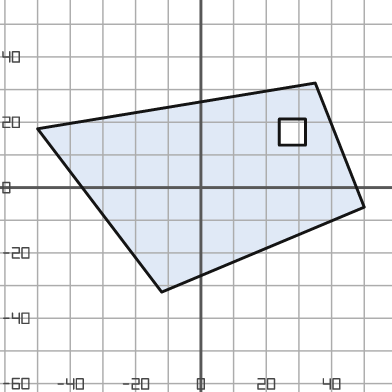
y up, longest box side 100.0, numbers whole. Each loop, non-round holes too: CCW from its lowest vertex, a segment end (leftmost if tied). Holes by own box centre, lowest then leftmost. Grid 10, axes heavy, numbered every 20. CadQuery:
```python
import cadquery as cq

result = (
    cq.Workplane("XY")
    .moveTo(-12.0, -32.0)
    .lineTo(50.0, -6.0)
    .lineTo(35.0, 32.0)
    .lineTo(-50.0, 18.0)
    .close()
    .moveTo(24.0, 13.0)
    .lineTo(32.0, 13.0)
    .lineTo(32.0, 21.0)
    .lineTo(24.0, 21.0)
    .close()
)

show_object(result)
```